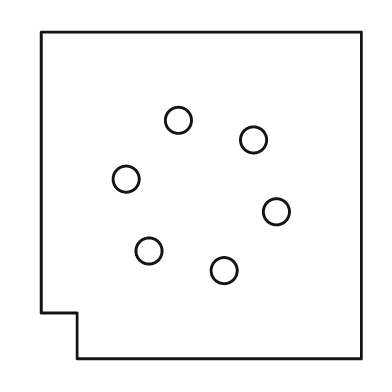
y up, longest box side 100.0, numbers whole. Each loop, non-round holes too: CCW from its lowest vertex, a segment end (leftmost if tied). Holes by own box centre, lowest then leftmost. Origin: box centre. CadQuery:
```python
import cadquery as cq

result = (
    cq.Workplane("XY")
    .moveTo(-38.0, -50.0)
    .lineTo(49.0, -50.0)
    .lineTo(49.0, 50.0)
    .lineTo(-49.0, 50.0)
    .lineTo(-49.0, -36.0)
    .lineTo(-38.0, -36.0)
    .close()
    .moveTo(7.0, -23.0)
    .circle(4.0)
    .moveTo(-16.0, -17.0)
    .circle(4.0)
    .moveTo(23.0, -5.0)
    .circle(4.0)
    .moveTo(-23.0, 5.0)
    .circle(4.0)
    .moveTo(16.0, 17.0)
    .circle(4.0)
    .moveTo(-7.0, 23.0)
    .circle(4.0)
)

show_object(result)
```